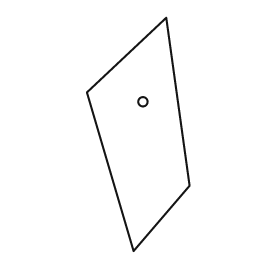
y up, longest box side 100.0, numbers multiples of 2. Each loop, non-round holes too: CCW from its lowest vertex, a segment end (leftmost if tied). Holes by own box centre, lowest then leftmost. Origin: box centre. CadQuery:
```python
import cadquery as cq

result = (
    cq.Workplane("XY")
    .moveTo(-2.0, -50.0)
    .lineTo(22.0, -22.0)
    .lineTo(12.0, 50.0)
    .lineTo(-22.0, 18.0)
    .close()
    .moveTo(2.0, 14.0)
    .circle(2.0)
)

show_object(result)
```